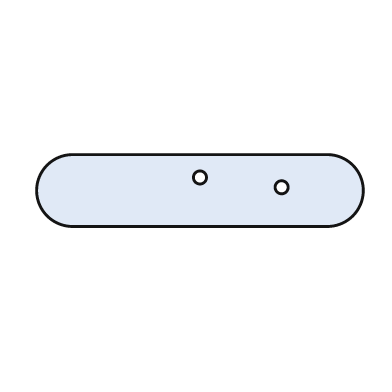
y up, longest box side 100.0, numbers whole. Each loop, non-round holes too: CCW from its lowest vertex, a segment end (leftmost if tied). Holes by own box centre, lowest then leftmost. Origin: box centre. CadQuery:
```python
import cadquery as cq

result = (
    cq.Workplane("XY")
    .moveTo(-39.0, -11.0)
    .lineTo(39.0, -11.0)
    .threePointArc((50.0, 0.0), (39.0, 11.0))
    .lineTo(-39.0, 11.0)
    .threePointArc((-50.0, 0.0), (-39.0, -11.0))
    .close()
    .moveTo(25.0, 1.0)
    .circle(2.0)
    .moveTo(0.0, 4.0)
    .circle(2.0)
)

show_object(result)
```